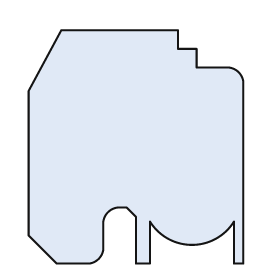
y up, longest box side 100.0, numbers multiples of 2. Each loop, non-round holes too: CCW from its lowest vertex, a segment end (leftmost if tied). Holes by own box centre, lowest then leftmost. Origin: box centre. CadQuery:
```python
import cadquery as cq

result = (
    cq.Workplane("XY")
    .moveTo(-34.0, -50.0)
    .lineTo(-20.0, -50.0)
    .threePointArc((-16.0, -48.0), (-14.0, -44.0))
    .lineTo(-14.0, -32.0)
    .threePointArc((-12.0, -28.0), (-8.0, -26.0))
    .lineTo(-4.0, -26.0)
    .lineTo(0.0, -30.0)
    .lineTo(0.0, -50.0)
    .lineTo(6.0, -50.0)
    .lineTo(6.0, -32.0)
    .threePointArc((24.0, -42.0), (42.0, -32.0))
    .lineTo(42.0, -50.0)
    .lineTo(46.0, -50.0)
    .lineTo(46.0, 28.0)
    .threePointArc((44.0, 32.0), (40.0, 34.0))
    .lineTo(26.0, 34.0)
    .lineTo(26.0, 42.0)
    .lineTo(18.0, 42.0)
    .lineTo(18.0, 50.0)
    .lineTo(-32.0, 50.0)
    .lineTo(-46.0, 24.0)
    .lineTo(-46.0, -38.0)
    .close()
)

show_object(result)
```